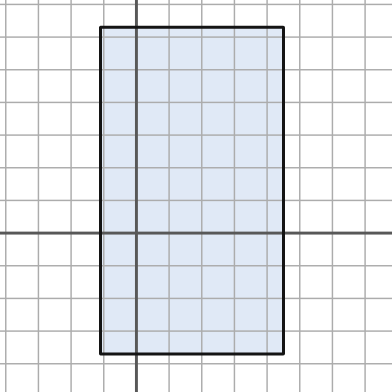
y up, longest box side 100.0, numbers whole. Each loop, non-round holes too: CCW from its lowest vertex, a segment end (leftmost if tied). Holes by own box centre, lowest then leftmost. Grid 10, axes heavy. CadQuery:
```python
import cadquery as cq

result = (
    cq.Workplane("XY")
    .moveTo(-11.0, -37.0)
    .lineTo(45.0, -37.0)
    .lineTo(45.0, 63.0)
    .lineTo(-11.0, 63.0)
    .close()
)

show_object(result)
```